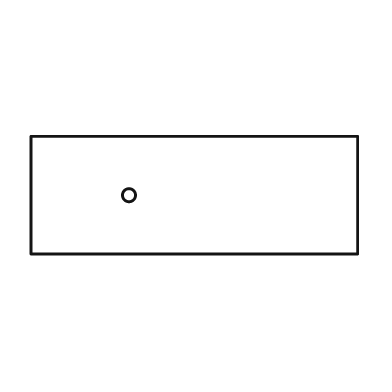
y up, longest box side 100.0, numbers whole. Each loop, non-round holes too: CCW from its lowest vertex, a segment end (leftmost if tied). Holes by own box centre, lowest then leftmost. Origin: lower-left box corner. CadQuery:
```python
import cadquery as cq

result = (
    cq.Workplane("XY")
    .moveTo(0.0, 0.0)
    .lineTo(100.0, 0.0)
    .lineTo(100.0, 36.0)
    .lineTo(0.0, 36.0)
    .close()
    .moveTo(30.0, 18.0)
    .circle(2.0)
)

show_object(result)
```